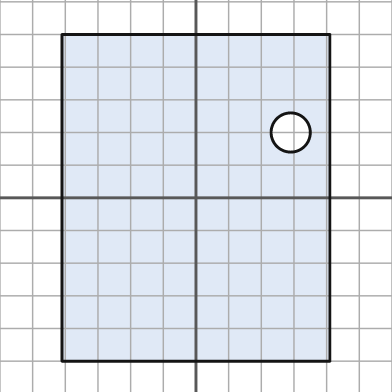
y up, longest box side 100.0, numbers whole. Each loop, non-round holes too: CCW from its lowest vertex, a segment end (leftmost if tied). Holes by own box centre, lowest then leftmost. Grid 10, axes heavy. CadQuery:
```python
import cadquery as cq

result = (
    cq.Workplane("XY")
    .moveTo(-41.0, -50.0)
    .lineTo(41.0, -50.0)
    .lineTo(41.0, 50.0)
    .lineTo(-41.0, 50.0)
    .close()
    .moveTo(29.0, 20.0)
    .circle(6.0)
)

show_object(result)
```